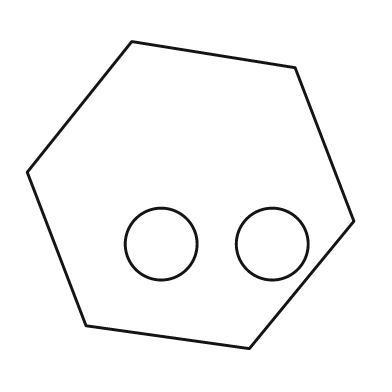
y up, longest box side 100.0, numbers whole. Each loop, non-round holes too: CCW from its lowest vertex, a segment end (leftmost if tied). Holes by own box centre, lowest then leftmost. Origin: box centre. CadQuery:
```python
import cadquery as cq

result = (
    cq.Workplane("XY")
    .moveTo(18.0, -47.0)
    .lineTo(50.0, -8.0)
    .lineTo(32.0, 39.0)
    .lineTo(-18.0, 47.0)
    .lineTo(-50.0, 7.0)
    .lineTo(-32.0, -40.0)
    .close()
    .moveTo(-9.0, -15.0)
    .circle(11.0)
    .moveTo(25.0, -15.0)
    .circle(11.0)
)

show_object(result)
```